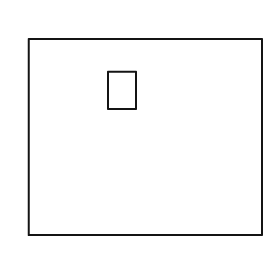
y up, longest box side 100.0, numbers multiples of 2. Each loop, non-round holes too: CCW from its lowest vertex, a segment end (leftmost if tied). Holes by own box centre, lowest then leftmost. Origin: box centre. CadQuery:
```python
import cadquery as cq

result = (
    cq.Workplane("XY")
    .moveTo(-50.0, -42.0)
    .lineTo(50.0, -42.0)
    .lineTo(50.0, 42.0)
    .lineTo(-50.0, 42.0)
    .close()
    .moveTo(-16.0, 12.0)
    .lineTo(-4.0, 12.0)
    .lineTo(-4.0, 28.0)
    .lineTo(-16.0, 28.0)
    .close()
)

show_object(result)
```